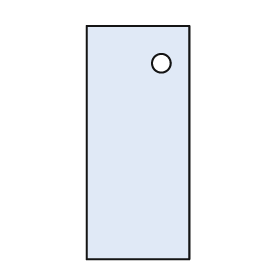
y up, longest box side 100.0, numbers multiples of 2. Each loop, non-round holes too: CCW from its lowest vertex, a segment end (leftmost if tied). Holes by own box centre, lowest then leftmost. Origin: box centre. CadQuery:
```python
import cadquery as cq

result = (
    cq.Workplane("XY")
    .moveTo(-22.0, -50.0)
    .lineTo(22.0, -50.0)
    .lineTo(22.0, 50.0)
    .lineTo(-22.0, 50.0)
    .close()
    .moveTo(10.0, 34.0)
    .circle(4.0)
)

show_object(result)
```